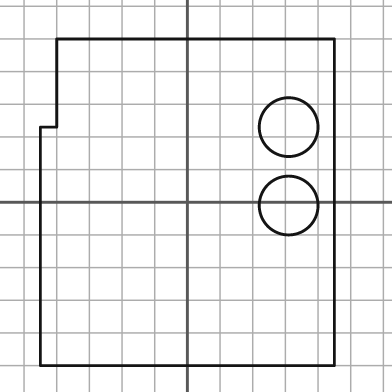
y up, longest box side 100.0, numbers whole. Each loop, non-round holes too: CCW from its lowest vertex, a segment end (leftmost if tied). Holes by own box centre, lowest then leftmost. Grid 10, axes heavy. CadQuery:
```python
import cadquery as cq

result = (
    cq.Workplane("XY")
    .moveTo(-45.0, -50.0)
    .lineTo(45.0, -50.0)
    .lineTo(45.0, 50.0)
    .lineTo(-40.0, 50.0)
    .lineTo(-40.0, 23.0)
    .lineTo(-45.0, 23.0)
    .close()
    .moveTo(31.0, -1.0)
    .circle(9.0)
    .moveTo(31.0, 23.0)
    .circle(9.0)
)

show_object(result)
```